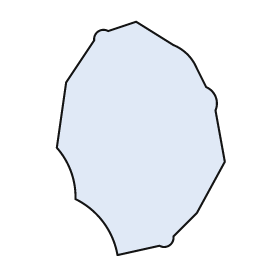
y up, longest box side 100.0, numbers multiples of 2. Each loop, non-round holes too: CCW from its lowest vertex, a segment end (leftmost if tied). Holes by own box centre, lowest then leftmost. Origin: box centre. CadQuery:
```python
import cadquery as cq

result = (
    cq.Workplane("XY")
    .moveTo(-10.0, -50.0)
    .lineTo(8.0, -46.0)
    .threePointArc((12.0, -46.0), (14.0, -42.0))
    .lineTo(24.0, -32.0)
    .lineTo(36.0, -10.0)
    .lineTo(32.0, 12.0)
    .threePointArc((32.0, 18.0), (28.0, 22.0))
    .lineTo(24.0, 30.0)
    .threePointArc((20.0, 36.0), (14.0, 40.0))
    .lineTo(-2.0, 50.0)
    .lineTo(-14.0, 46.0)
    .threePointArc((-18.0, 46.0), (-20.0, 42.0))
    .lineTo(-32.0, 24.0)
    .lineTo(-36.0, -4.0)
    .threePointArc((-30.0, -14.0), (-28.0, -26.0))
    .threePointArc((-16.0, -36.0), (-10.0, -50.0))
    .close()
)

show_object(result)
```